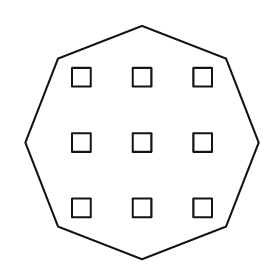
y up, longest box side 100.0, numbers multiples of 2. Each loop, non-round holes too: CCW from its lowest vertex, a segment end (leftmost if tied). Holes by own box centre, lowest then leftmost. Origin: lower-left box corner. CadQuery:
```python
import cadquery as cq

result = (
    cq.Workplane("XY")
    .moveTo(50.0, 0.0)
    .lineTo(86.0, 14.0)
    .lineTo(100.0, 50.0)
    .lineTo(86.0, 86.0)
    .lineTo(50.0, 100.0)
    .lineTo(14.0, 86.0)
    .lineTo(0.0, 50.0)
    .lineTo(14.0, 14.0)
    .close()
    .moveTo(20.0, 18.0)
    .lineTo(28.0, 18.0)
    .lineTo(28.0, 26.0)
    .lineTo(20.0, 26.0)
    .close()
    .moveTo(46.0, 18.0)
    .lineTo(54.0, 18.0)
    .lineTo(54.0, 26.0)
    .lineTo(46.0, 26.0)
    .close()
    .moveTo(72.0, 18.0)
    .lineTo(80.0, 18.0)
    .lineTo(80.0, 26.0)
    .lineTo(72.0, 26.0)
    .close()
    .moveTo(20.0, 46.0)
    .lineTo(28.0, 46.0)
    .lineTo(28.0, 54.0)
    .lineTo(20.0, 54.0)
    .close()
    .moveTo(46.0, 46.0)
    .lineTo(54.0, 46.0)
    .lineTo(54.0, 54.0)
    .lineTo(46.0, 54.0)
    .close()
    .moveTo(72.0, 46.0)
    .lineTo(80.0, 46.0)
    .lineTo(80.0, 54.0)
    .lineTo(72.0, 54.0)
    .close()
    .moveTo(20.0, 74.0)
    .lineTo(28.0, 74.0)
    .lineTo(28.0, 82.0)
    .lineTo(20.0, 82.0)
    .close()
    .moveTo(46.0, 74.0)
    .lineTo(54.0, 74.0)
    .lineTo(54.0, 82.0)
    .lineTo(46.0, 82.0)
    .close()
    .moveTo(72.0, 74.0)
    .lineTo(80.0, 74.0)
    .lineTo(80.0, 82.0)
    .lineTo(72.0, 82.0)
    .close()
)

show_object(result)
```